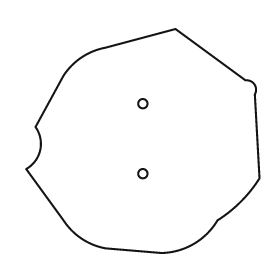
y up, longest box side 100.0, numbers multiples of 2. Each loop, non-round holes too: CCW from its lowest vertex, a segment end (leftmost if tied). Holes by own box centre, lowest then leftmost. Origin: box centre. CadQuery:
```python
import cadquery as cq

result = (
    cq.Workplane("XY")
    .moveTo(8.0, -48.0)
    .threePointArc((22.0, -44.0), (32.0, -34.0))
    .threePointArc((42.0, -26.0), (50.0, -16.0))
    .lineTo(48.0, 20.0)
    .threePointArc((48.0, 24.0), (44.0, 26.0))
    .lineTo(14.0, 48.0)
    .lineTo(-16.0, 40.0)
    .threePointArc((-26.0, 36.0), (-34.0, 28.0))
    .lineTo(-46.0, 6.0)
    .threePointArc((-44.0, -4.0), (-50.0, -12.0))
    .lineTo(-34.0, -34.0)
    .threePointArc((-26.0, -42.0), (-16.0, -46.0))
    .close()
    .moveTo(0.0, -14.0)
    .circle(2.0)
    .moveTo(0.0, 16.0)
    .circle(2.0)
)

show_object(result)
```